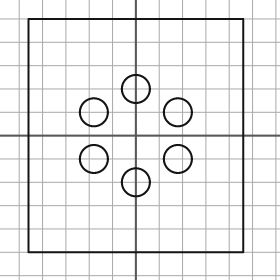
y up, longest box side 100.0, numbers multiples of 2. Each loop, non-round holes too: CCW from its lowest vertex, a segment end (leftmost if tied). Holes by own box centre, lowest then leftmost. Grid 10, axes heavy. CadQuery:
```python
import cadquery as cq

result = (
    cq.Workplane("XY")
    .moveTo(-46.0, -50.0)
    .lineTo(46.0, -50.0)
    .lineTo(46.0, 50.0)
    .lineTo(-46.0, 50.0)
    .close()
    .moveTo(0.0, -20.0)
    .circle(6.0)
    .moveTo(-18.0, -10.0)
    .circle(6.0)
    .moveTo(18.0, -10.0)
    .circle(6.0)
    .moveTo(-18.0, 10.0)
    .circle(6.0)
    .moveTo(18.0, 10.0)
    .circle(6.0)
    .moveTo(0.0, 20.0)
    .circle(6.0)
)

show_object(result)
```